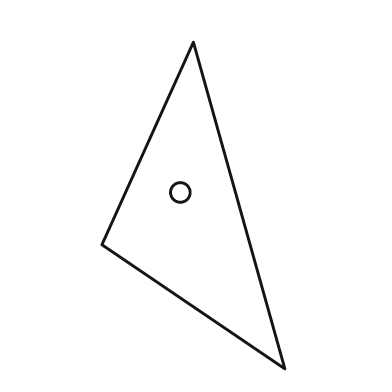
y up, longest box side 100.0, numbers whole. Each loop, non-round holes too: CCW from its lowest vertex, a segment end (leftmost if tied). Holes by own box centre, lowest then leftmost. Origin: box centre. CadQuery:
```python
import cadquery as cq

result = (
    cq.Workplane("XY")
    .moveTo(28.0, -50.0)
    .lineTo(0.0, 50.0)
    .lineTo(-28.0, -12.0)
    .close()
    .moveTo(-4.0, 4.0)
    .circle(3.0)
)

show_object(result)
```